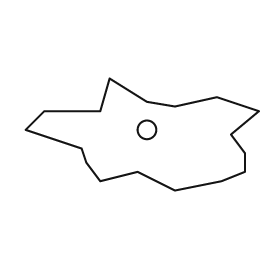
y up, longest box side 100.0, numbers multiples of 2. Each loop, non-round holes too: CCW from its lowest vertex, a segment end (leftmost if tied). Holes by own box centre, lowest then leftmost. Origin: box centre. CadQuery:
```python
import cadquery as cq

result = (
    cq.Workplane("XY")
    .moveTo(14.0, -24.0)
    .lineTo(34.0, -20.0)
    .lineTo(44.0, -16.0)
    .lineTo(44.0, -8.0)
    .lineTo(38.0, 0.0)
    .lineTo(50.0, 10.0)
    .lineTo(32.0, 16.0)
    .lineTo(14.0, 12.0)
    .lineTo(2.0, 14.0)
    .lineTo(-14.0, 24.0)
    .lineTo(-18.0, 10.0)
    .lineTo(-42.0, 10.0)
    .lineTo(-50.0, 2.0)
    .lineTo(-26.0, -6.0)
    .lineTo(-24.0, -12.0)
    .lineTo(-18.0, -20.0)
    .lineTo(-2.0, -16.0)
    .close()
    .moveTo(2.0, 2.0)
    .circle(4.0)
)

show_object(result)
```